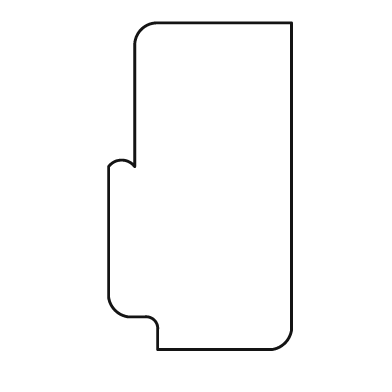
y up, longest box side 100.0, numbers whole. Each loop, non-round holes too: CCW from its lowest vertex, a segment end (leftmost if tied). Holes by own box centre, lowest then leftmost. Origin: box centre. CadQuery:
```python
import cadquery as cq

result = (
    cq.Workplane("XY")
    .moveTo(-13.0, -50.0)
    .lineTo(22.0, -50.0)
    .threePointArc((26.0, -48.0), (28.0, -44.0))
    .lineTo(28.0, 50.0)
    .lineTo(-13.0, 50.0)
    .threePointArc((-18.0, 48.0), (-20.0, 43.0))
    .lineTo(-20.0, 6.0)
    .threePointArc((-24.0, 8.0), (-28.0, 6.0))
    .lineTo(-28.0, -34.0)
    .threePointArc((-26.0, -38.0), (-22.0, -40.0))
    .lineTo(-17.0, -40.0)
    .threePointArc((-14.0, -41.0), (-13.0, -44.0))
    .close()
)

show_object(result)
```